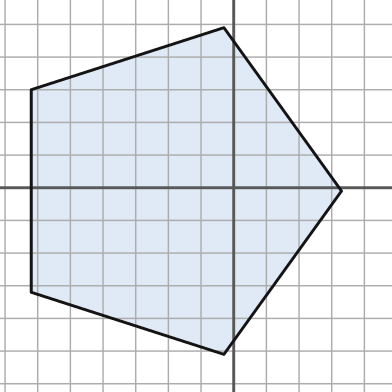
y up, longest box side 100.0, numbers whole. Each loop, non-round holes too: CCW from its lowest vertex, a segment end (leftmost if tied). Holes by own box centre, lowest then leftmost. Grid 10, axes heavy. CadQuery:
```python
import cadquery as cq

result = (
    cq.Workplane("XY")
    .moveTo(-3.0, -51.0)
    .lineTo(33.0, -1.0)
    .lineTo(-3.0, 49.0)
    .lineTo(-62.0, 30.0)
    .lineTo(-62.0, -32.0)
    .close()
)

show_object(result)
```